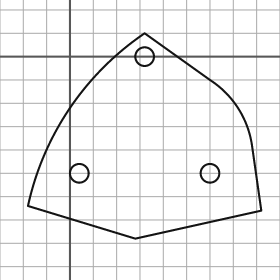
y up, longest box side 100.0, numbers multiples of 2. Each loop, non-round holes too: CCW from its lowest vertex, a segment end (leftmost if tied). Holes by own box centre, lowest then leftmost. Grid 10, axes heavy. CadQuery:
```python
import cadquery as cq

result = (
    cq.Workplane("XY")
    .moveTo(28.0, -78.0)
    .lineTo(82.0, -66.0)
    .lineTo(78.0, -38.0)
    .threePointArc((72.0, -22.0), (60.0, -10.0))
    .lineTo(32.0, 10.0)
    .threePointArc((0.0, -22.0), (-18.0, -64.0))
    .close()
    .moveTo(4.0, -50.0)
    .circle(4.0)
    .moveTo(60.0, -50.0)
    .circle(4.0)
    .moveTo(32.0, 0.0)
    .circle(4.0)
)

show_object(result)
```